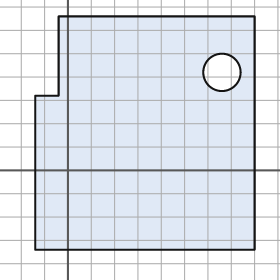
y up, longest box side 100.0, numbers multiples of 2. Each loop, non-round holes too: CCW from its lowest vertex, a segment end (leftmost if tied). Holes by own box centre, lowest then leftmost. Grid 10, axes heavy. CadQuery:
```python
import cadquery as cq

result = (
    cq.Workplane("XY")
    .moveTo(-14.0, -34.0)
    .lineTo(80.0, -34.0)
    .lineTo(80.0, 66.0)
    .lineTo(-4.0, 66.0)
    .lineTo(-4.0, 32.0)
    .lineTo(-14.0, 32.0)
    .close()
    .moveTo(66.0, 42.0)
    .circle(8.0)
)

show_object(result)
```